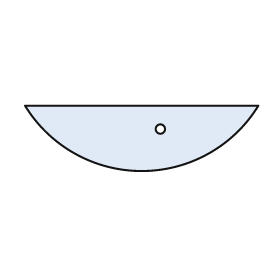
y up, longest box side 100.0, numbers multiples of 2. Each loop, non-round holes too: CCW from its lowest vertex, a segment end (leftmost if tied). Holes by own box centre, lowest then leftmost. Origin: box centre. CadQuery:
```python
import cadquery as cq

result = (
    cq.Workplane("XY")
    .moveTo(-50.0, 14.0)
    .threePointArc((0.0, -14.0), (50.0, 14.0))
    .close()
    .moveTo(8.0, 4.0)
    .circle(2.0)
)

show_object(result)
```